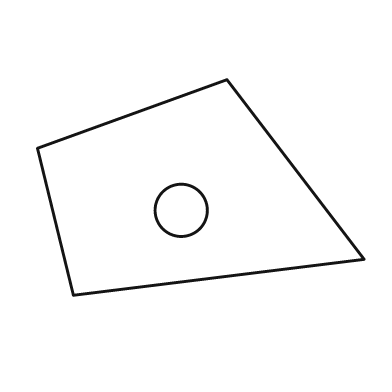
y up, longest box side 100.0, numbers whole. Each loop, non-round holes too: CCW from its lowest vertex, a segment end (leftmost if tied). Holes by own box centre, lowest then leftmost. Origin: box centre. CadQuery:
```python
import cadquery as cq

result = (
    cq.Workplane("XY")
    .moveTo(-39.0, -33.0)
    .lineTo(50.0, -22.0)
    .lineTo(8.0, 33.0)
    .lineTo(-50.0, 12.0)
    .close()
    .moveTo(-6.0, -7.0)
    .circle(8.0)
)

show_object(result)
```